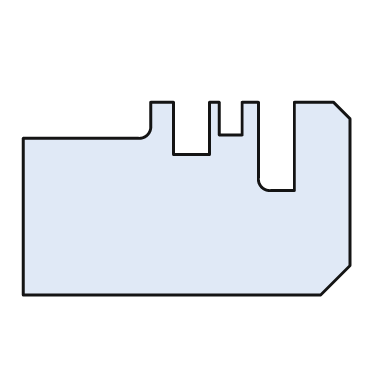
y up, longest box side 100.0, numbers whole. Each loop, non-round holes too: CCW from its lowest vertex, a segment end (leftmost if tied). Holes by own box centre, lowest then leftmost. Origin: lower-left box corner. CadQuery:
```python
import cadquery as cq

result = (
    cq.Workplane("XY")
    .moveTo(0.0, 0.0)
    .lineTo(91.0, 0.0)
    .lineTo(100.0, 9.0)
    .lineTo(100.0, 54.0)
    .lineTo(95.0, 59.0)
    .lineTo(83.0, 59.0)
    .lineTo(83.0, 32.0)
    .lineTo(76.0, 32.0)
    .threePointArc((73.0, 33.0), (72.0, 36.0))
    .lineTo(72.0, 59.0)
    .lineTo(67.0, 59.0)
    .lineTo(67.0, 49.0)
    .lineTo(60.0, 49.0)
    .lineTo(60.0, 59.0)
    .lineTo(57.0, 59.0)
    .lineTo(57.0, 43.0)
    .lineTo(46.0, 43.0)
    .lineTo(46.0, 59.0)
    .lineTo(39.0, 59.0)
    .lineTo(39.0, 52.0)
    .threePointArc((38.0, 49.0), (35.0, 48.0))
    .lineTo(0.0, 48.0)
    .close()
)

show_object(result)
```